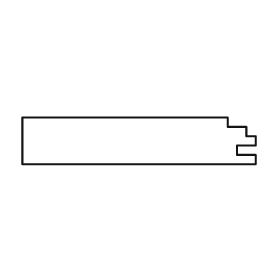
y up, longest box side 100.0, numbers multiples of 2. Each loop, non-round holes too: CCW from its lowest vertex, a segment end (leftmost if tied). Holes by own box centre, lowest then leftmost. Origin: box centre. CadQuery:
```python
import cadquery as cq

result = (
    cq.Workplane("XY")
    .moveTo(-50.0, -10.0)
    .lineTo(50.0, -10.0)
    .lineTo(50.0, -6.0)
    .lineTo(42.0, -6.0)
    .lineTo(42.0, -2.0)
    .lineTo(50.0, -2.0)
    .lineTo(50.0, 2.0)
    .lineTo(46.0, 2.0)
    .lineTo(46.0, 6.0)
    .lineTo(38.0, 6.0)
    .lineTo(38.0, 10.0)
    .lineTo(-50.0, 10.0)
    .close()
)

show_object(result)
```